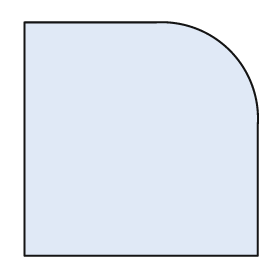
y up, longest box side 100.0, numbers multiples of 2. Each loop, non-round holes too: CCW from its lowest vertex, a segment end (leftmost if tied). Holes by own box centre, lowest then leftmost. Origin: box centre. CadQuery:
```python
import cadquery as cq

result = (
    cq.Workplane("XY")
    .moveTo(-50.0, -50.0)
    .lineTo(50.0, -50.0)
    .lineTo(50.0, 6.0)
    .threePointArc((38.0, 38.0), (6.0, 50.0))
    .lineTo(-50.0, 50.0)
    .close()
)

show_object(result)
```